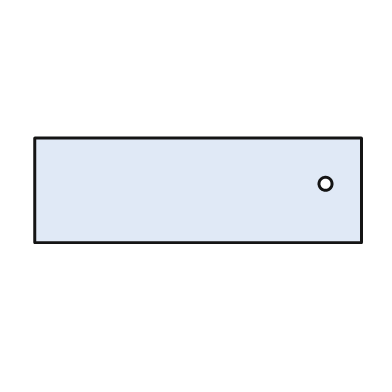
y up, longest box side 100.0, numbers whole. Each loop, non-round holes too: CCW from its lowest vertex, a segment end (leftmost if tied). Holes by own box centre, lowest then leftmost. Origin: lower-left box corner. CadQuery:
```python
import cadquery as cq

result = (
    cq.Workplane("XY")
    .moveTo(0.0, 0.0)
    .lineTo(100.0, 0.0)
    .lineTo(100.0, 32.0)
    .lineTo(0.0, 32.0)
    .close()
    .moveTo(89.0, 18.0)
    .circle(2.0)
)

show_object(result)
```